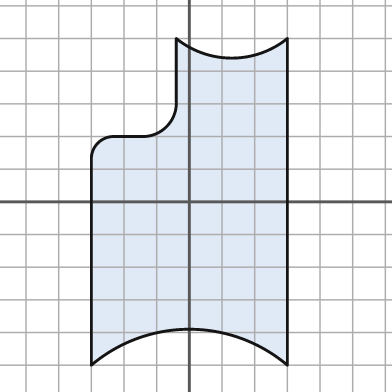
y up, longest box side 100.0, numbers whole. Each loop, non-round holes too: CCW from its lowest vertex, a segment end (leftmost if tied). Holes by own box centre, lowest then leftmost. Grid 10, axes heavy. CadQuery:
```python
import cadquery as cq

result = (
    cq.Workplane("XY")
    .moveTo(-30.0, -50.0)
    .threePointArc((0.0, -39.0), (30.0, -50.0))
    .lineTo(30.0, 50.0)
    .threePointArc((13.0, 44.0), (-4.0, 50.0))
    .lineTo(-4.0, 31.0)
    .threePointArc((-7.0, 23.0), (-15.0, 20.0))
    .lineTo(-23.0, 20.0)
    .threePointArc((-28.0, 18.0), (-30.0, 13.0))
    .close()
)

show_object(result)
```